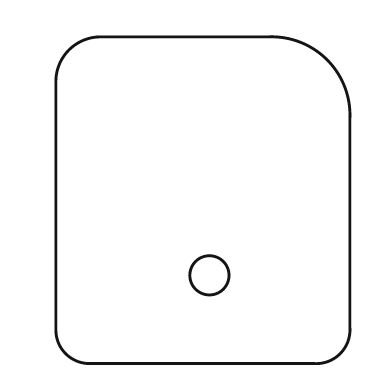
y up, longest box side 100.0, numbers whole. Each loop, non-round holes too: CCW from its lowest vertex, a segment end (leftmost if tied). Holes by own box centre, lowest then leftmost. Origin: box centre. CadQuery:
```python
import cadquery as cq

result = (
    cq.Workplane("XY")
    .moveTo(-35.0, -50.0)
    .lineTo(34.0, -50.0)
    .threePointArc((42.0, -47.0), (45.0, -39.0))
    .lineTo(45.0, 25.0)
    .threePointArc((38.0, 43.0), (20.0, 50.0))
    .lineTo(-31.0, 50.0)
    .threePointArc((-41.0, 46.0), (-45.0, 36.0))
    .lineTo(-45.0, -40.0)
    .threePointArc((-42.0, -47.0), (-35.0, -50.0))
    .close()
    .moveTo(2.0, -23.0)
    .circle(6.0)
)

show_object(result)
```